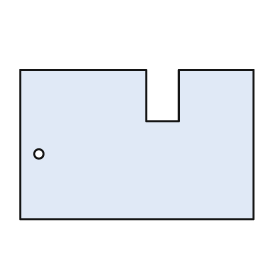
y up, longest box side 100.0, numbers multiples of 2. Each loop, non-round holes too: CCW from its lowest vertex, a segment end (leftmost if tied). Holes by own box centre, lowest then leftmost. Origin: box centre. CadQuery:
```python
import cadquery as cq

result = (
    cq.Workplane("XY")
    .moveTo(-50.0, -32.0)
    .lineTo(50.0, -32.0)
    .lineTo(50.0, 32.0)
    .lineTo(18.0, 32.0)
    .lineTo(18.0, 10.0)
    .lineTo(4.0, 10.0)
    .lineTo(4.0, 32.0)
    .lineTo(-50.0, 32.0)
    .close()
    .moveTo(-42.0, -4.0)
    .circle(2.0)
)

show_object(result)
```